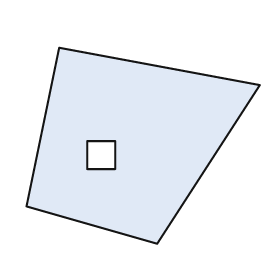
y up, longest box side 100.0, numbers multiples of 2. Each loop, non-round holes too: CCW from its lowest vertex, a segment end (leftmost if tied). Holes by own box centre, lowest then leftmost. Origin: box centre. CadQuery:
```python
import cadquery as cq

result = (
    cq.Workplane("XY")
    .moveTo(6.0, -42.0)
    .lineTo(50.0, 26.0)
    .lineTo(-36.0, 42.0)
    .lineTo(-50.0, -26.0)
    .close()
    .moveTo(-24.0, -10.0)
    .lineTo(-12.0, -10.0)
    .lineTo(-12.0, 2.0)
    .lineTo(-24.0, 2.0)
    .close()
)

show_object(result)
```